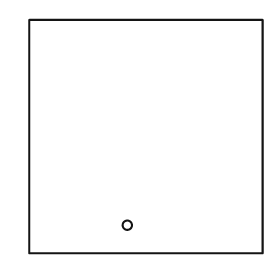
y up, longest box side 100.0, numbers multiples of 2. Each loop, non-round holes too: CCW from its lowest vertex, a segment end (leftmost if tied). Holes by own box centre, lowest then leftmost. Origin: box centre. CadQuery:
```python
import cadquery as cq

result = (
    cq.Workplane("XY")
    .moveTo(-50.0, -50.0)
    .lineTo(50.0, -50.0)
    .lineTo(50.0, 50.0)
    .lineTo(-50.0, 50.0)
    .close()
    .moveTo(-8.0, -38.0)
    .circle(2.0)
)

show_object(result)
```